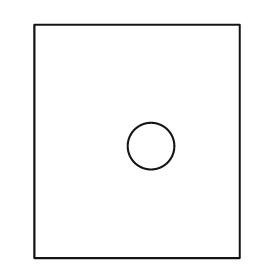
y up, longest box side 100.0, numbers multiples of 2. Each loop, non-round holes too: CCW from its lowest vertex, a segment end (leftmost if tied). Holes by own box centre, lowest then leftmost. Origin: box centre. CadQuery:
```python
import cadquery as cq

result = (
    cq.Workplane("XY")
    .moveTo(-44.0, -50.0)
    .lineTo(44.0, -50.0)
    .lineTo(44.0, 50.0)
    .lineTo(-44.0, 50.0)
    .close()
    .moveTo(6.0, -2.0)
    .circle(10.0)
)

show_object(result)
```